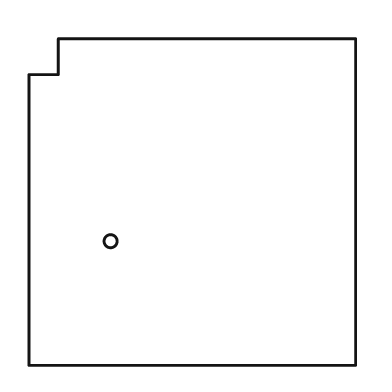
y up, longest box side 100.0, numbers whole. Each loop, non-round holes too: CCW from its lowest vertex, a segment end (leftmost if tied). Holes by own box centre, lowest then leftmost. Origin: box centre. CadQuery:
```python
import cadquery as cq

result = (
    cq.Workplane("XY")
    .moveTo(-50.0, -50.0)
    .lineTo(50.0, -50.0)
    .lineTo(50.0, 50.0)
    .lineTo(-41.0, 50.0)
    .lineTo(-41.0, 39.0)
    .lineTo(-50.0, 39.0)
    .close()
    .moveTo(-25.0, -12.0)
    .circle(2.0)
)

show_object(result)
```